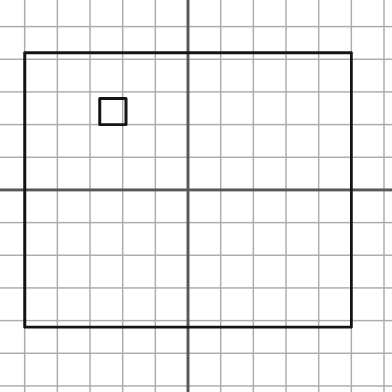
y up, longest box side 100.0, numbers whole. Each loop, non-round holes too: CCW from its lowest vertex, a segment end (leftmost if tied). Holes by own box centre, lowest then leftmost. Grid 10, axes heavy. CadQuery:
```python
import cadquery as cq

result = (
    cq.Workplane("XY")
    .moveTo(-50.0, -42.0)
    .lineTo(50.0, -42.0)
    .lineTo(50.0, 42.0)
    .lineTo(-50.0, 42.0)
    .close()
    .moveTo(-27.0, 20.0)
    .lineTo(-19.0, 20.0)
    .lineTo(-19.0, 28.0)
    .lineTo(-27.0, 28.0)
    .close()
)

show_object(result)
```